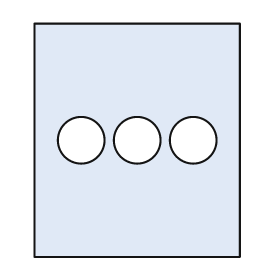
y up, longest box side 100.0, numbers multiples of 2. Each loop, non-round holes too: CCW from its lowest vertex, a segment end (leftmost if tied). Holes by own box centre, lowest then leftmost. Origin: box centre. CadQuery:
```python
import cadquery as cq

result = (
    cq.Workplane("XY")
    .moveTo(-44.0, -50.0)
    .lineTo(44.0, -50.0)
    .lineTo(44.0, 50.0)
    .lineTo(-44.0, 50.0)
    .close()
    .moveTo(-24.0, 0.0)
    .circle(10.0)
    .moveTo(0.0, 0.0)
    .circle(10.0)
    .moveTo(24.0, 0.0)
    .circle(10.0)
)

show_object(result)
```